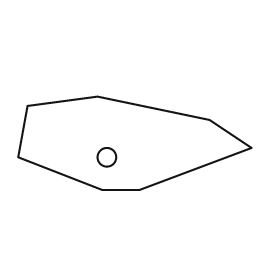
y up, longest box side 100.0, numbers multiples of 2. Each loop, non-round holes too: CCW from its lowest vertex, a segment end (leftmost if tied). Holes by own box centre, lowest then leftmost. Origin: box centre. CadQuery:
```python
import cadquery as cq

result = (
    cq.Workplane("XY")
    .moveTo(-14.0, -20.0)
    .lineTo(2.0, -20.0)
    .lineTo(50.0, -2.0)
    .lineTo(32.0, 10.0)
    .lineTo(-16.0, 20.0)
    .lineTo(-46.0, 16.0)
    .lineTo(-50.0, -6.0)
    .close()
    .moveTo(-12.0, -6.0)
    .circle(4.0)
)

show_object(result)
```